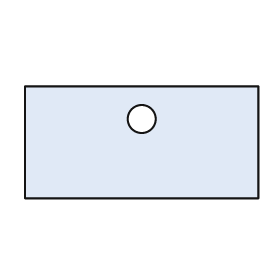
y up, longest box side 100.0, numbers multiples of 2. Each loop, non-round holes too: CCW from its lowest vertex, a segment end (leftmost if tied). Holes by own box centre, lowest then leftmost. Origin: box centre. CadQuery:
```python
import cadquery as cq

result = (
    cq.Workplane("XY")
    .moveTo(-50.0, -24.0)
    .lineTo(50.0, -24.0)
    .lineTo(50.0, 24.0)
    .lineTo(-50.0, 24.0)
    .close()
    .moveTo(0.0, 10.0)
    .circle(6.0)
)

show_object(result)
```